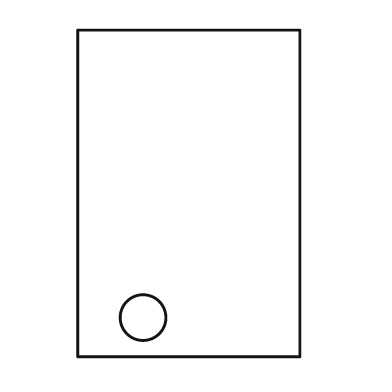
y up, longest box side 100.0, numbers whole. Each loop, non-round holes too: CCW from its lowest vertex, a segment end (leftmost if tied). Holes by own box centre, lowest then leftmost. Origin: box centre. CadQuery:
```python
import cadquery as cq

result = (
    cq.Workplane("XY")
    .moveTo(-34.0, -50.0)
    .lineTo(34.0, -50.0)
    .lineTo(34.0, 50.0)
    .lineTo(-34.0, 50.0)
    .close()
    .moveTo(-14.0, -38.0)
    .circle(7.0)
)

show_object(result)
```